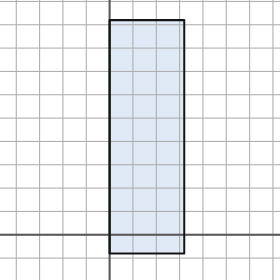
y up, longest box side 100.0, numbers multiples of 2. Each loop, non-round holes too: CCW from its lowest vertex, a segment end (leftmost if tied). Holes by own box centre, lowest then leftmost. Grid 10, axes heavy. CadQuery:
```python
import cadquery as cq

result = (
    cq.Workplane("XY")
    .moveTo(0.0, -8.0)
    .lineTo(32.0, -8.0)
    .lineTo(32.0, 92.0)
    .lineTo(0.0, 92.0)
    .close()
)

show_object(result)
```